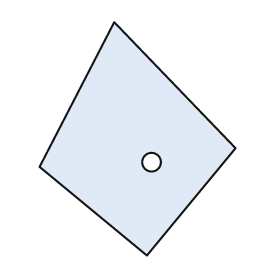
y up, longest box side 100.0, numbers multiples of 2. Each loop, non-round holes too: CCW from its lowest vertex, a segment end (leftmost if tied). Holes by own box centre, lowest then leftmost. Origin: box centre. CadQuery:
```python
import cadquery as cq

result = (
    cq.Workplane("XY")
    .moveTo(4.0, -50.0)
    .lineTo(42.0, -4.0)
    .lineTo(-10.0, 50.0)
    .lineTo(-42.0, -12.0)
    .close()
    .moveTo(6.0, -10.0)
    .circle(4.0)
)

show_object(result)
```